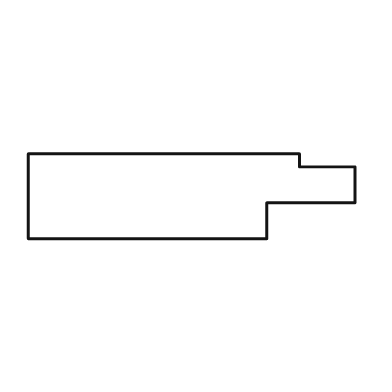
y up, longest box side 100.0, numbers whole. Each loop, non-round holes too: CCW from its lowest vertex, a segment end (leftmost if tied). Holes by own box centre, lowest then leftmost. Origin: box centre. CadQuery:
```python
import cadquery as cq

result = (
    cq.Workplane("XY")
    .moveTo(-50.0, -13.0)
    .lineTo(23.0, -13.0)
    .lineTo(23.0, -2.0)
    .lineTo(50.0, -2.0)
    .lineTo(50.0, 9.0)
    .lineTo(33.0, 9.0)
    .lineTo(33.0, 13.0)
    .lineTo(-50.0, 13.0)
    .close()
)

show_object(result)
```